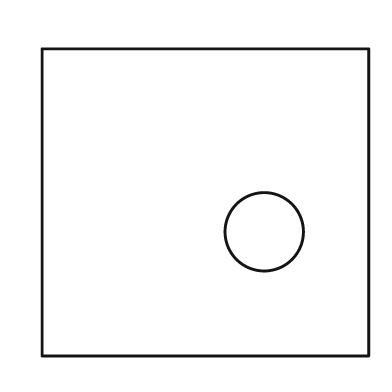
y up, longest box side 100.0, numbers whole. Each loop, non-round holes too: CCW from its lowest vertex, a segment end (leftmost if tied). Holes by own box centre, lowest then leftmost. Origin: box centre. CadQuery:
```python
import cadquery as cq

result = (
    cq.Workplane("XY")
    .moveTo(-50.0, -47.0)
    .lineTo(50.0, -47.0)
    .lineTo(50.0, 47.0)
    .lineTo(-50.0, 47.0)
    .close()
    .moveTo(18.0, -9.0)
    .circle(12.0)
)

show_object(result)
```